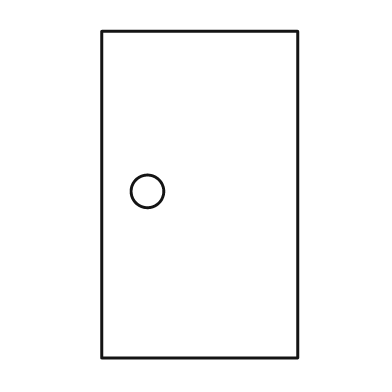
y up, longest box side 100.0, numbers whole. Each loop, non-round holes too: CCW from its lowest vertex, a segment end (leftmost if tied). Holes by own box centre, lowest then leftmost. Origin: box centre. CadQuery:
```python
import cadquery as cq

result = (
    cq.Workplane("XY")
    .moveTo(-30.0, -50.0)
    .lineTo(30.0, -50.0)
    .lineTo(30.0, 50.0)
    .lineTo(-30.0, 50.0)
    .close()
    .moveTo(-16.0, 1.0)
    .circle(5.0)
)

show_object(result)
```